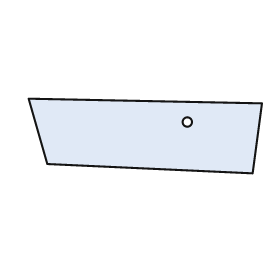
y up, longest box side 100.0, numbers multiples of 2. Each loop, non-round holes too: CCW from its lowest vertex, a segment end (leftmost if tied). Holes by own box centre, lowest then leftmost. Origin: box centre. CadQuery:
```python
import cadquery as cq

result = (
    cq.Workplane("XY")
    .moveTo(46.0, -16.0)
    .lineTo(50.0, 14.0)
    .lineTo(-50.0, 16.0)
    .lineTo(-42.0, -12.0)
    .close()
    .moveTo(18.0, 6.0)
    .circle(2.0)
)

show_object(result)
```